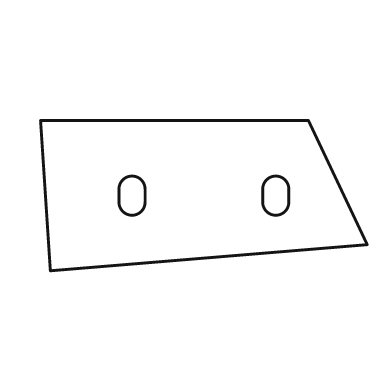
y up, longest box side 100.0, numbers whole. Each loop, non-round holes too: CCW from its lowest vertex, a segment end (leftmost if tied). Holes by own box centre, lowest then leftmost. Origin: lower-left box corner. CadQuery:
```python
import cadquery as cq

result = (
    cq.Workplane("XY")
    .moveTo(3.0, 0.0)
    .lineTo(100.0, 8.0)
    .lineTo(82.0, 46.0)
    .lineTo(0.0, 46.0)
    .close()
    .moveTo(24.0, 21.0)
    .threePointArc((28.0, 17.0), (32.0, 21.0))
    .lineTo(32.0, 25.0)
    .threePointArc((28.0, 29.0), (24.0, 25.0))
    .close()
    .moveTo(68.0, 21.0)
    .threePointArc((72.0, 17.0), (76.0, 21.0))
    .lineTo(76.0, 25.0)
    .threePointArc((72.0, 29.0), (68.0, 25.0))
    .close()
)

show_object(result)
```